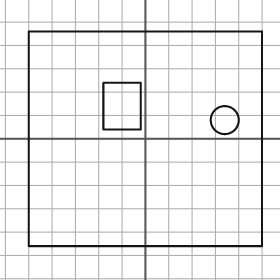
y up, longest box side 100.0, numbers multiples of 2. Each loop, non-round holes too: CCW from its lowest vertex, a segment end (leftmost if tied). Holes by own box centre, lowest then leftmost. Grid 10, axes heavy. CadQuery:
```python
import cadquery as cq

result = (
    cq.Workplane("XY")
    .moveTo(-50.0, -46.0)
    .lineTo(50.0, -46.0)
    .lineTo(50.0, 46.0)
    .lineTo(-50.0, 46.0)
    .close()
    .moveTo(34.0, 8.0)
    .circle(6.0)
    .moveTo(-18.0, 4.0)
    .lineTo(-2.0, 4.0)
    .lineTo(-2.0, 24.0)
    .lineTo(-18.0, 24.0)
    .close()
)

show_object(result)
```